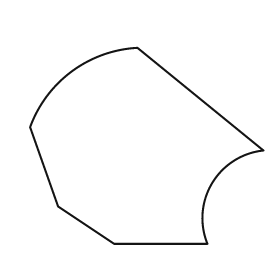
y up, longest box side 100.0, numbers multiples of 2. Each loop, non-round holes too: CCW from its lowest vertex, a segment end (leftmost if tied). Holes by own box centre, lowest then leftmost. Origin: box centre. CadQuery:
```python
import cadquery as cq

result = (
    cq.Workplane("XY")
    .moveTo(-14.0, -42.0)
    .lineTo(26.0, -42.0)
    .threePointArc((28.0, -16.0), (50.0, -2.0))
    .lineTo(-4.0, 42.0)
    .threePointArc((-32.0, 32.0), (-50.0, 8.0))
    .lineTo(-38.0, -26.0)
    .close()
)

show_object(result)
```